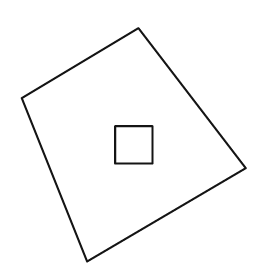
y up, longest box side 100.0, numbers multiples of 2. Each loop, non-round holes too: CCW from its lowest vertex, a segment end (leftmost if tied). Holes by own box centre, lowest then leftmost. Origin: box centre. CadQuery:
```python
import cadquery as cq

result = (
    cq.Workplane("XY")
    .moveTo(-20.0, -50.0)
    .lineTo(48.0, -10.0)
    .lineTo(2.0, 50.0)
    .lineTo(-48.0, 20.0)
    .close()
    .moveTo(-8.0, -8.0)
    .lineTo(8.0, -8.0)
    .lineTo(8.0, 8.0)
    .lineTo(-8.0, 8.0)
    .close()
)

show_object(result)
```